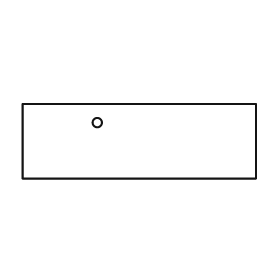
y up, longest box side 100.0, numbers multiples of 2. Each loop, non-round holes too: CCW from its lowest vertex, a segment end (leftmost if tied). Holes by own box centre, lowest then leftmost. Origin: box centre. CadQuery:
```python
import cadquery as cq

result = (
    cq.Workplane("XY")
    .moveTo(-50.0, -16.0)
    .lineTo(50.0, -16.0)
    .lineTo(50.0, 16.0)
    .lineTo(-50.0, 16.0)
    .close()
    .moveTo(-18.0, 8.0)
    .circle(2.0)
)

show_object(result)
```